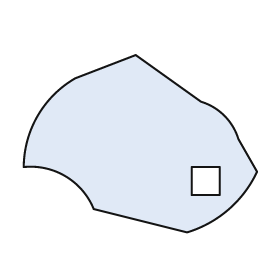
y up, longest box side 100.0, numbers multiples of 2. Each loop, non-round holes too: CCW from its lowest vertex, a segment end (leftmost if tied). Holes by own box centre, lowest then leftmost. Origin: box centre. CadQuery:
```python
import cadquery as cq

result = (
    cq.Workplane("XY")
    .moveTo(20.0, -38.0)
    .threePointArc((38.0, -28.0), (50.0, -12.0))
    .lineTo(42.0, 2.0)
    .threePointArc((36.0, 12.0), (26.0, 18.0))
    .lineTo(-2.0, 38.0)
    .lineTo(-28.0, 28.0)
    .threePointArc((-44.0, 12.0), (-50.0, -10.0))
    .threePointArc((-32.0, -14.0), (-20.0, -28.0))
    .close()
    .moveTo(22.0, -22.0)
    .lineTo(34.0, -22.0)
    .lineTo(34.0, -10.0)
    .lineTo(22.0, -10.0)
    .close()
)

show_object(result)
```